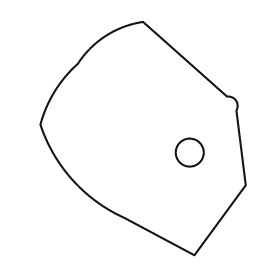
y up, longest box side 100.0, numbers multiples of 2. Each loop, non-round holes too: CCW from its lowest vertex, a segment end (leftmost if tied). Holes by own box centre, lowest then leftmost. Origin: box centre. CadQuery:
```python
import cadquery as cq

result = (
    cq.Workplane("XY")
    .moveTo(22.0, -50.0)
    .lineTo(44.0, -20.0)
    .lineTo(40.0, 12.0)
    .threePointArc((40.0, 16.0), (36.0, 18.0))
    .lineTo(0.0, 50.0)
    .threePointArc((-16.0, 44.0), (-28.0, 32.0))
    .threePointArc((-38.0, 20.0), (-44.0, 6.0))
    .threePointArc((-30.0, -18.0), (-8.0, -34.0))
    .close()
    .moveTo(20.0, -6.0)
    .circle(6.0)
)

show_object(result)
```